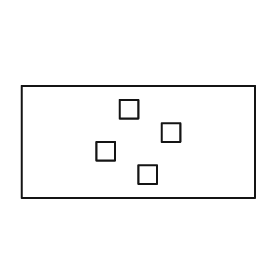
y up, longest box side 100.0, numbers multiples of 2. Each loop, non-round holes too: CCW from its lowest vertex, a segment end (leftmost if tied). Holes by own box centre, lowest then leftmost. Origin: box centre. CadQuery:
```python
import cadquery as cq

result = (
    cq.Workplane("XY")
    .moveTo(-50.0, -24.0)
    .lineTo(50.0, -24.0)
    .lineTo(50.0, 24.0)
    .lineTo(-50.0, 24.0)
    .close()
    .moveTo(0.0, -18.0)
    .lineTo(8.0, -18.0)
    .lineTo(8.0, -10.0)
    .lineTo(0.0, -10.0)
    .close()
    .moveTo(-18.0, -8.0)
    .lineTo(-10.0, -8.0)
    .lineTo(-10.0, 0.0)
    .lineTo(-18.0, 0.0)
    .close()
    .moveTo(10.0, 0.0)
    .lineTo(18.0, 0.0)
    .lineTo(18.0, 8.0)
    .lineTo(10.0, 8.0)
    .close()
    .moveTo(-8.0, 10.0)
    .lineTo(0.0, 10.0)
    .lineTo(0.0, 18.0)
    .lineTo(-8.0, 18.0)
    .close()
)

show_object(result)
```